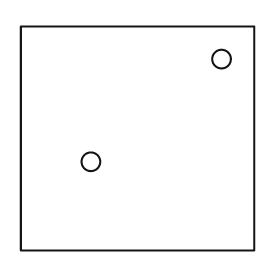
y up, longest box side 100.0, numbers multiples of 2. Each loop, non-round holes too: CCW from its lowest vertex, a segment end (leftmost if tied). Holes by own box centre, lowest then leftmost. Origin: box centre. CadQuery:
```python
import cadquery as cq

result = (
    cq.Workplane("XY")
    .moveTo(-50.0, -48.0)
    .lineTo(50.0, -48.0)
    .lineTo(50.0, 48.0)
    .lineTo(-50.0, 48.0)
    .close()
    .moveTo(-20.0, -10.0)
    .circle(4.0)
    .moveTo(36.0, 34.0)
    .circle(4.0)
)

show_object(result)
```